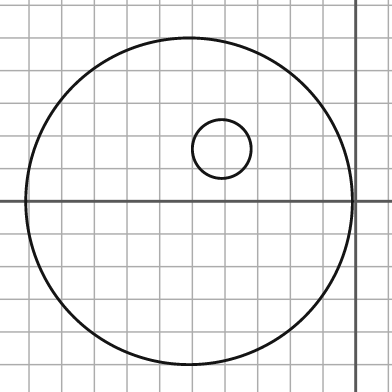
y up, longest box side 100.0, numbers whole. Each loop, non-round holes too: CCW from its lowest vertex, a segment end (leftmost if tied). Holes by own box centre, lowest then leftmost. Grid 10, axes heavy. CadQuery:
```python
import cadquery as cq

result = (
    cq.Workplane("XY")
    .moveTo(-51.0, 0.0)
    .circle(50.0)
    .moveTo(-41.0, 16.0)
    .circle(9.0)
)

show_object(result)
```